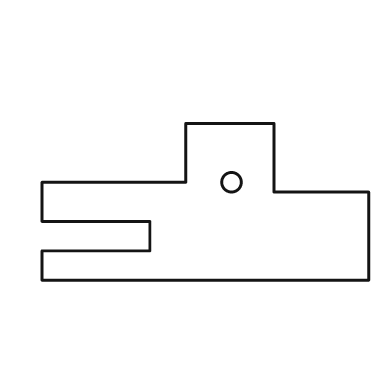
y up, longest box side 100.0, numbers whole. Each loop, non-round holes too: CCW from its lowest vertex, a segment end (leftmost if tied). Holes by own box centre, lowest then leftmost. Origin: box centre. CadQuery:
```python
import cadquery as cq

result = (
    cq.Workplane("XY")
    .moveTo(-50.0, -24.0)
    .lineTo(50.0, -24.0)
    .lineTo(50.0, 3.0)
    .lineTo(21.0, 3.0)
    .lineTo(21.0, 24.0)
    .lineTo(-6.0, 24.0)
    .lineTo(-6.0, 6.0)
    .lineTo(-50.0, 6.0)
    .lineTo(-50.0, -6.0)
    .lineTo(-17.0, -6.0)
    .lineTo(-17.0, -15.0)
    .lineTo(-50.0, -15.0)
    .close()
    .moveTo(8.0, 6.0)
    .circle(3.0)
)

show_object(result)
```